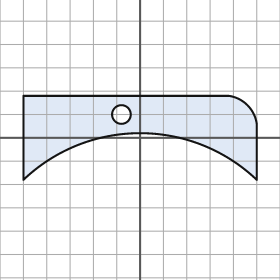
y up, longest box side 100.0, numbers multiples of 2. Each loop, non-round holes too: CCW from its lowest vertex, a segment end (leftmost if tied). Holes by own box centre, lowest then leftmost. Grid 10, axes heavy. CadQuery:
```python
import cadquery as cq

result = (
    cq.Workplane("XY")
    .moveTo(-50.0, -18.0)
    .threePointArc((0.0, 2.0), (50.0, -18.0))
    .lineTo(50.0, 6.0)
    .threePointArc((46.0, 14.0), (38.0, 18.0))
    .lineTo(-50.0, 18.0)
    .close()
    .moveTo(-8.0, 10.0)
    .circle(4.0)
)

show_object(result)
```